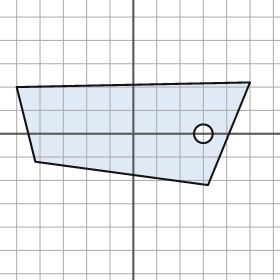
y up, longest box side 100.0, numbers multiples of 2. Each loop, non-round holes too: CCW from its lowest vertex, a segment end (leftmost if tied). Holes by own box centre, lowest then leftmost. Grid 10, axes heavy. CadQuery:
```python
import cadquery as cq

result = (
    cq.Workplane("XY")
    .moveTo(32.0, -22.0)
    .lineTo(50.0, 22.0)
    .lineTo(-50.0, 20.0)
    .lineTo(-42.0, -12.0)
    .close()
    .moveTo(30.0, 0.0)
    .circle(4.0)
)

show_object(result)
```